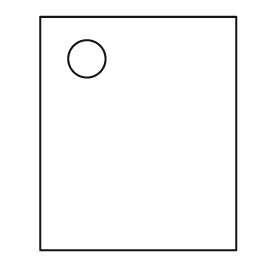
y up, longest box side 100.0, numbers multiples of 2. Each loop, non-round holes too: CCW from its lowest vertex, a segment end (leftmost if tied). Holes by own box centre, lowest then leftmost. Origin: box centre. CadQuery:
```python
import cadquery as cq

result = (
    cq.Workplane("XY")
    .moveTo(-42.0, -50.0)
    .lineTo(42.0, -50.0)
    .lineTo(42.0, 50.0)
    .lineTo(-42.0, 50.0)
    .close()
    .moveTo(-22.0, 32.0)
    .circle(8.0)
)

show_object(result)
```